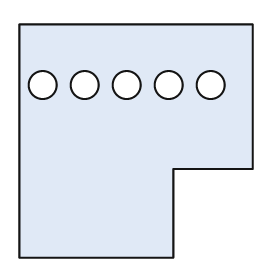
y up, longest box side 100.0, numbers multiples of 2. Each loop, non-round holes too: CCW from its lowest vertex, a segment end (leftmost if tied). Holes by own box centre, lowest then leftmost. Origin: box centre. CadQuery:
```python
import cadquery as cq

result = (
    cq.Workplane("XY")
    .moveTo(-50.0, -50.0)
    .lineTo(16.0, -50.0)
    .lineTo(16.0, -12.0)
    .lineTo(50.0, -12.0)
    .lineTo(50.0, 50.0)
    .lineTo(-50.0, 50.0)
    .close()
    .moveTo(-40.0, 24.0)
    .circle(6.0)
    .moveTo(-22.0, 24.0)
    .circle(6.0)
    .moveTo(-4.0, 24.0)
    .circle(6.0)
    .moveTo(14.0, 24.0)
    .circle(6.0)
    .moveTo(32.0, 24.0)
    .circle(6.0)
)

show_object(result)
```